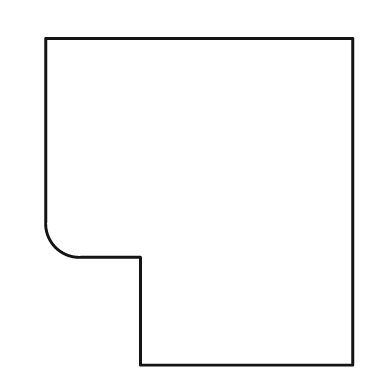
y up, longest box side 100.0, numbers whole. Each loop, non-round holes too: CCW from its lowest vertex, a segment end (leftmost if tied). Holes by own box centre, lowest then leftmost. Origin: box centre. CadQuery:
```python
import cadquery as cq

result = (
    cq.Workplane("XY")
    .moveTo(-18.0, -50.0)
    .lineTo(47.0, -50.0)
    .lineTo(47.0, 50.0)
    .lineTo(-47.0, 50.0)
    .lineTo(-47.0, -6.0)
    .threePointArc((-44.0, -14.0), (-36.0, -17.0))
    .lineTo(-18.0, -17.0)
    .close()
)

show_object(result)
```